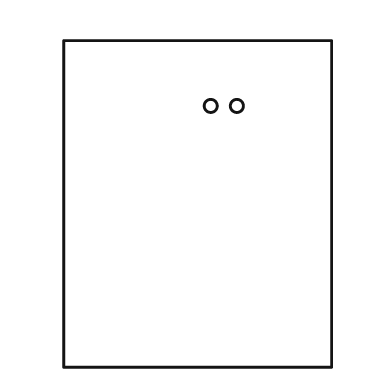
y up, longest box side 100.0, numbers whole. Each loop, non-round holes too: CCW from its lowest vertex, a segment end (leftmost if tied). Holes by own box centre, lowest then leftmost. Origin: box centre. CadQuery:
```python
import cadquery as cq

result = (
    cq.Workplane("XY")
    .moveTo(-41.0, -50.0)
    .lineTo(41.0, -50.0)
    .lineTo(41.0, 50.0)
    .lineTo(-41.0, 50.0)
    .close()
    .moveTo(4.0, 30.0)
    .circle(2.0)
    .moveTo(12.0, 30.0)
    .circle(2.0)
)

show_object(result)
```